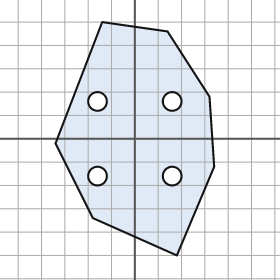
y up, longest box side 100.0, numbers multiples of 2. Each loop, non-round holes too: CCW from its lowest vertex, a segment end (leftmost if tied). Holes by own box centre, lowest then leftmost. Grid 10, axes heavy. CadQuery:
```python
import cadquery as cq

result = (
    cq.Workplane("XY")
    .moveTo(18.0, -50.0)
    .lineTo(34.0, -12.0)
    .lineTo(32.0, 18.0)
    .lineTo(14.0, 46.0)
    .lineTo(-14.0, 50.0)
    .lineTo(-34.0, -2.0)
    .lineTo(-18.0, -34.0)
    .close()
    .moveTo(-16.0, -16.0)
    .circle(4.0)
    .moveTo(16.0, -16.0)
    .circle(4.0)
    .moveTo(-16.0, 16.0)
    .circle(4.0)
    .moveTo(16.0, 16.0)
    .circle(4.0)
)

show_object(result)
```